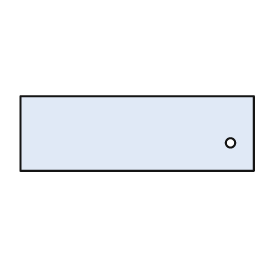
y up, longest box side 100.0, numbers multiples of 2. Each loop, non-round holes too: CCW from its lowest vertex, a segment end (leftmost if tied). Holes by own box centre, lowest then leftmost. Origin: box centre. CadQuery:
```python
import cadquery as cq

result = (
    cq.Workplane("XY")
    .moveTo(-50.0, -16.0)
    .lineTo(50.0, -16.0)
    .lineTo(50.0, 16.0)
    .lineTo(-50.0, 16.0)
    .close()
    .moveTo(40.0, -4.0)
    .circle(2.0)
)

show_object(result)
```